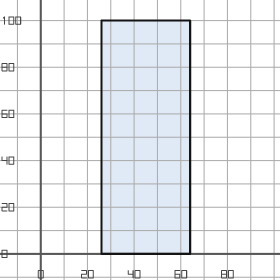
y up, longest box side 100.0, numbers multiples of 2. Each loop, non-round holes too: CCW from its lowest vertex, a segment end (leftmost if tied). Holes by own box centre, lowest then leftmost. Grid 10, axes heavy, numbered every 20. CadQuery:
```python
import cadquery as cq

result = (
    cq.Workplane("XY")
    .moveTo(26.0, 0.0)
    .lineTo(64.0, 0.0)
    .lineTo(64.0, 100.0)
    .lineTo(26.0, 100.0)
    .close()
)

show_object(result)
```